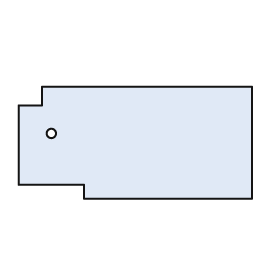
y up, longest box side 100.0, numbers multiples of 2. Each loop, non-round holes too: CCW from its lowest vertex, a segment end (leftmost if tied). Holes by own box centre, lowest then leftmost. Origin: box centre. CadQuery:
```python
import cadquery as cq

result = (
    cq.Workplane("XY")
    .moveTo(-22.0, -24.0)
    .lineTo(50.0, -24.0)
    .lineTo(50.0, 24.0)
    .lineTo(-40.0, 24.0)
    .lineTo(-40.0, 16.0)
    .lineTo(-50.0, 16.0)
    .lineTo(-50.0, -18.0)
    .lineTo(-22.0, -18.0)
    .close()
    .moveTo(-36.0, 4.0)
    .circle(2.0)
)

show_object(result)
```